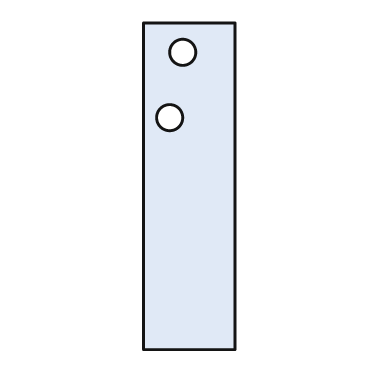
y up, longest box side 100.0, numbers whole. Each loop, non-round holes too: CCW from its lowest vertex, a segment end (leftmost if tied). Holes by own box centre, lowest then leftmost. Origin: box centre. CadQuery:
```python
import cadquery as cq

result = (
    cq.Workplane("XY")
    .moveTo(-14.0, -50.0)
    .lineTo(14.0, -50.0)
    .lineTo(14.0, 50.0)
    .lineTo(-14.0, 50.0)
    .close()
    .moveTo(-6.0, 21.0)
    .circle(4.0)
    .moveTo(-2.0, 41.0)
    .circle(4.0)
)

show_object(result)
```